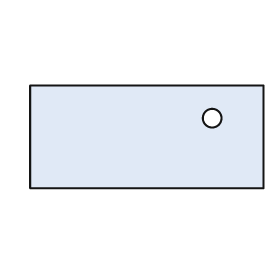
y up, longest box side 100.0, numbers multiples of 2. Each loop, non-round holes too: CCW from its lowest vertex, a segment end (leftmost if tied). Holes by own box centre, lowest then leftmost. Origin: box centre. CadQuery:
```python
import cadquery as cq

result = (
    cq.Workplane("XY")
    .moveTo(-50.0, -22.0)
    .lineTo(50.0, -22.0)
    .lineTo(50.0, 22.0)
    .lineTo(-50.0, 22.0)
    .close()
    .moveTo(28.0, 8.0)
    .circle(4.0)
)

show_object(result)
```